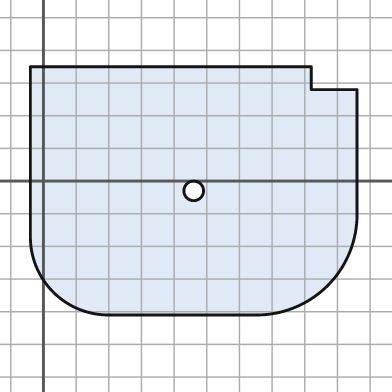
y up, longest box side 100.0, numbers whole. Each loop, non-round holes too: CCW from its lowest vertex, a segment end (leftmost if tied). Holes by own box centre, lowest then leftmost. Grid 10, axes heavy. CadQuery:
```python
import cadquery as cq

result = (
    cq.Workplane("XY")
    .moveTo(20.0, -41.0)
    .lineTo(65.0, -41.0)
    .threePointArc((87.0, -32.0), (96.0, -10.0))
    .lineTo(96.0, 28.0)
    .lineTo(82.0, 28.0)
    .lineTo(82.0, 35.0)
    .lineTo(-4.0, 35.0)
    .lineTo(-4.0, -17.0)
    .threePointArc((3.0, -34.0), (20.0, -41.0))
    .close()
    .moveTo(46.0, -3.0)
    .circle(3.0)
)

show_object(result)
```